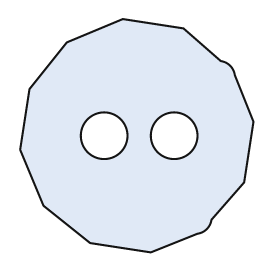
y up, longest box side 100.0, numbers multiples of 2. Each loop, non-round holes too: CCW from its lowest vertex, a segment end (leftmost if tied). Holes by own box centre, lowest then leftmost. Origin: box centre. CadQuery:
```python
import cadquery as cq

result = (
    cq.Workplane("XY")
    .moveTo(6.0, -50.0)
    .lineTo(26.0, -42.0)
    .threePointArc((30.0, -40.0), (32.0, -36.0))
    .lineTo(46.0, -20.0)
    .lineTo(50.0, 6.0)
    .lineTo(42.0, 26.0)
    .threePointArc((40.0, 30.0), (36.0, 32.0))
    .lineTo(20.0, 46.0)
    .lineTo(-6.0, 50.0)
    .lineTo(-30.0, 40.0)
    .lineTo(-46.0, 20.0)
    .lineTo(-50.0, -6.0)
    .lineTo(-40.0, -30.0)
    .lineTo(-20.0, -46.0)
    .close()
    .moveTo(-14.0, 0.0)
    .circle(10.0)
    .moveTo(16.0, 0.0)
    .circle(10.0)
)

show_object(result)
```